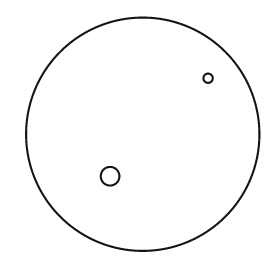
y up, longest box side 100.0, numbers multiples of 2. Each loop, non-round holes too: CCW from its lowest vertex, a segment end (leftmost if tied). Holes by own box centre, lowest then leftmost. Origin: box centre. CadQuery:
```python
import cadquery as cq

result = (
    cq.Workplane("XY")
    .moveTo(0.0, 0.0)
    .circle(50.0)
    .moveTo(-14.0, -18.0)
    .circle(4.0)
    .moveTo(28.0, 24.0)
    .circle(2.0)
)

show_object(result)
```